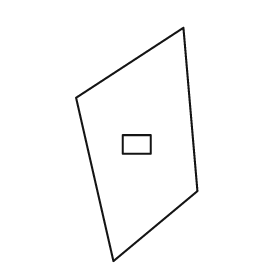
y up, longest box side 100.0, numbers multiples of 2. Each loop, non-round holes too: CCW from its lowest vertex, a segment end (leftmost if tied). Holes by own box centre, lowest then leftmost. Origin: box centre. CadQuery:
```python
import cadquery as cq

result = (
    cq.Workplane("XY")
    .moveTo(-10.0, -50.0)
    .lineTo(26.0, -20.0)
    .lineTo(20.0, 50.0)
    .lineTo(-26.0, 20.0)
    .close()
    .moveTo(-6.0, -4.0)
    .lineTo(6.0, -4.0)
    .lineTo(6.0, 4.0)
    .lineTo(-6.0, 4.0)
    .close()
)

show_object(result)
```